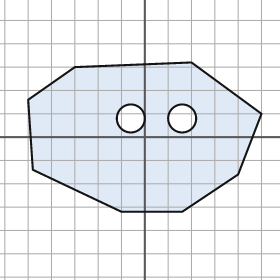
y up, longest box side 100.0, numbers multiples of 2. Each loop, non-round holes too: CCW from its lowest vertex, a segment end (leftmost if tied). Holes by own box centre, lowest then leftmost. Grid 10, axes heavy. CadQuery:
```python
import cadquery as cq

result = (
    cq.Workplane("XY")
    .moveTo(-10.0, -32.0)
    .lineTo(16.0, -32.0)
    .lineTo(40.0, -16.0)
    .lineTo(50.0, 10.0)
    .lineTo(20.0, 32.0)
    .lineTo(-30.0, 30.0)
    .lineTo(-50.0, 16.0)
    .lineTo(-48.0, -14.0)
    .close()
    .moveTo(-6.0, 8.0)
    .circle(6.0)
    .moveTo(16.0, 8.0)
    .circle(6.0)
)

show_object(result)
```